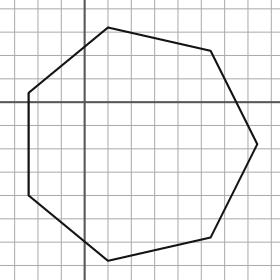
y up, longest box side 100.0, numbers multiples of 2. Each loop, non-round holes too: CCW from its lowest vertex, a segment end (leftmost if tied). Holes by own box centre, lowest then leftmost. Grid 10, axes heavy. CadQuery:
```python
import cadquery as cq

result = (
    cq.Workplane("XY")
    .moveTo(10.0, -68.0)
    .lineTo(54.0, -58.0)
    .lineTo(74.0, -18.0)
    .lineTo(54.0, 22.0)
    .lineTo(10.0, 32.0)
    .lineTo(-24.0, 4.0)
    .lineTo(-24.0, -40.0)
    .close()
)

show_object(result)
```